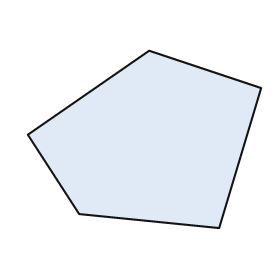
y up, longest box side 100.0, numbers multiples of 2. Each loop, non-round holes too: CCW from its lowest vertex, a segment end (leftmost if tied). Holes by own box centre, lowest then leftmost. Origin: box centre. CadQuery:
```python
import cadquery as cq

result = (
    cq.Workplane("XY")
    .moveTo(32.0, -38.0)
    .lineTo(50.0, 22.0)
    .lineTo(2.0, 38.0)
    .lineTo(-50.0, 2.0)
    .lineTo(-28.0, -32.0)
    .close()
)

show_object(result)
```